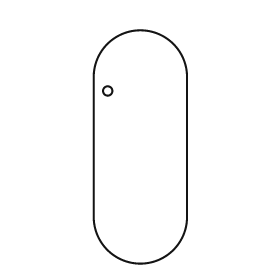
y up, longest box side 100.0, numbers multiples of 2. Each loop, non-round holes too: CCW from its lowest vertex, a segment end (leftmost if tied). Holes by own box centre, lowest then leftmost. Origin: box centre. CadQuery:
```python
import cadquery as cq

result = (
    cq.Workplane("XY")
    .moveTo(-20.0, -30.0)
    .threePointArc((0.0, -50.0), (20.0, -30.0))
    .lineTo(20.0, 30.0)
    .threePointArc((0.0, 50.0), (-20.0, 30.0))
    .close()
    .moveTo(-14.0, 24.0)
    .circle(2.0)
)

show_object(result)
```